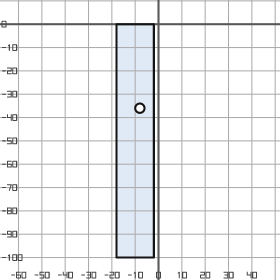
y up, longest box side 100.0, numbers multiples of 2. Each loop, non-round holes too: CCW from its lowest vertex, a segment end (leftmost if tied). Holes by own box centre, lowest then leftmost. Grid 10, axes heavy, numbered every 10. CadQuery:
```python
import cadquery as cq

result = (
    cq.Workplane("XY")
    .moveTo(-18.0, -100.0)
    .lineTo(-2.0, -100.0)
    .lineTo(-2.0, 0.0)
    .lineTo(-18.0, 0.0)
    .close()
    .moveTo(-8.0, -36.0)
    .circle(2.0)
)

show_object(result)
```